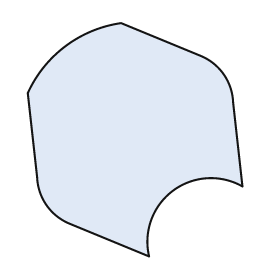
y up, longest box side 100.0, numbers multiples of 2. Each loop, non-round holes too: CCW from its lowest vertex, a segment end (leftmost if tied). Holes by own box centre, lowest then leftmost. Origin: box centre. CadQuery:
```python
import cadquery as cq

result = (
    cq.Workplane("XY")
    .moveTo(6.0, -50.0)
    .threePointArc((16.0, -22.0), (46.0, -20.0))
    .lineTo(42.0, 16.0)
    .threePointArc((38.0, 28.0), (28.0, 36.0))
    .lineTo(-6.0, 50.0)
    .threePointArc((-30.0, 40.0), (-46.0, 20.0))
    .lineTo(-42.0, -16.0)
    .threePointArc((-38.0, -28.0), (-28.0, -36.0))
    .close()
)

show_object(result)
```